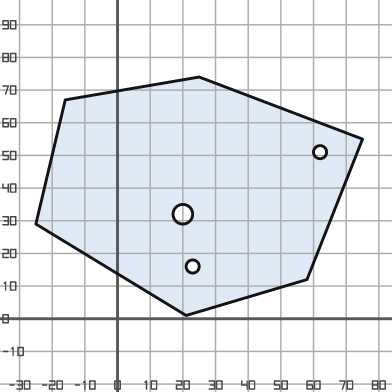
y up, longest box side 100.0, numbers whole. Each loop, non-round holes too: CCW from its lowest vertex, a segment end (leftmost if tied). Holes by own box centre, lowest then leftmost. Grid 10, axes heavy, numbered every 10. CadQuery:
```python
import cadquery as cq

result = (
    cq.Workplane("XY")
    .moveTo(21.0, 1.0)
    .lineTo(58.0, 12.0)
    .lineTo(75.0, 55.0)
    .lineTo(25.0, 74.0)
    .lineTo(-16.0, 67.0)
    .lineTo(-25.0, 29.0)
    .close()
    .moveTo(23.0, 16.0)
    .circle(2.0)
    .moveTo(20.0, 32.0)
    .circle(3.0)
    .moveTo(62.0, 51.0)
    .circle(2.0)
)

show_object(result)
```